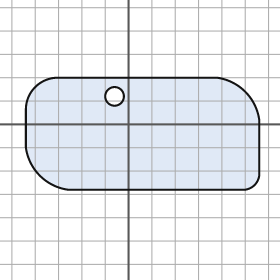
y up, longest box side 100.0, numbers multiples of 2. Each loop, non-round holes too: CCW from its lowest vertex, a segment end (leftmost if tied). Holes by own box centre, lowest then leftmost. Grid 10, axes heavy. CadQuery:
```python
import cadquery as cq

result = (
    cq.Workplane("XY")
    .moveTo(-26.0, -28.0)
    .lineTo(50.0, -28.0)
    .threePointArc((54.0, -26.0), (56.0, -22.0))
    .lineTo(56.0, 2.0)
    .threePointArc((50.0, 14.0), (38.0, 20.0))
    .lineTo(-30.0, 20.0)
    .threePointArc((-40.0, 16.0), (-44.0, 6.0))
    .lineTo(-44.0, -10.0)
    .threePointArc((-38.0, -22.0), (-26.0, -28.0))
    .close()
    .moveTo(-6.0, 12.0)
    .circle(4.0)
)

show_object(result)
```